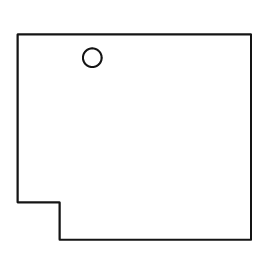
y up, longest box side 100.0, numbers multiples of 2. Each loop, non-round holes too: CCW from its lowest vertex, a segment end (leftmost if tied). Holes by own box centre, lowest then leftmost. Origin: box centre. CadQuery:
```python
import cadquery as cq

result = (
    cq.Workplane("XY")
    .moveTo(-32.0, -44.0)
    .lineTo(50.0, -44.0)
    .lineTo(50.0, 44.0)
    .lineTo(-50.0, 44.0)
    .lineTo(-50.0, -28.0)
    .lineTo(-32.0, -28.0)
    .close()
    .moveTo(-18.0, 34.0)
    .circle(4.0)
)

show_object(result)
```